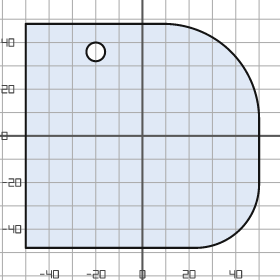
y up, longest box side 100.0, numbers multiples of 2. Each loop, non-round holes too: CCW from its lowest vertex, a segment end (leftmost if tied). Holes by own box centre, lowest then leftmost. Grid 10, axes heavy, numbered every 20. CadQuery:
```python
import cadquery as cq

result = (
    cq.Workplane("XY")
    .moveTo(-50.0, -48.0)
    .lineTo(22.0, -48.0)
    .threePointArc((42.0, -40.0), (50.0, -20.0))
    .lineTo(50.0, 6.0)
    .threePointArc((38.0, 36.0), (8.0, 48.0))
    .lineTo(-50.0, 48.0)
    .close()
    .moveTo(-20.0, 36.0)
    .circle(4.0)
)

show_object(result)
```